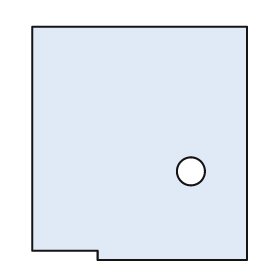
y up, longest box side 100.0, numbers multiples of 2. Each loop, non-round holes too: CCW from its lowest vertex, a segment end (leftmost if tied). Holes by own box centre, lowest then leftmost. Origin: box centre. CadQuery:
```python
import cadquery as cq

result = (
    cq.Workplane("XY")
    .moveTo(-18.0, -50.0)
    .lineTo(46.0, -50.0)
    .lineTo(46.0, 50.0)
    .lineTo(-46.0, 50.0)
    .lineTo(-46.0, -46.0)
    .lineTo(-18.0, -46.0)
    .close()
    .moveTo(22.0, -12.0)
    .circle(6.0)
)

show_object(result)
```